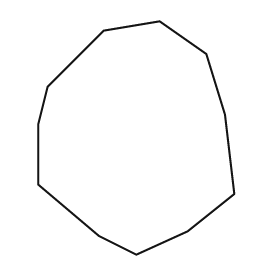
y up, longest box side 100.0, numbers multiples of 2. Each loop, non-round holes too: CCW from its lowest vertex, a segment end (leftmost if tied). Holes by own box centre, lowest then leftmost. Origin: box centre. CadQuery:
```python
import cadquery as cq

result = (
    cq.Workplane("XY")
    .moveTo(0.0, -50.0)
    .lineTo(22.0, -40.0)
    .lineTo(42.0, -24.0)
    .lineTo(38.0, 10.0)
    .lineTo(30.0, 36.0)
    .lineTo(10.0, 50.0)
    .lineTo(-14.0, 46.0)
    .lineTo(-38.0, 22.0)
    .lineTo(-42.0, 6.0)
    .lineTo(-42.0, -20.0)
    .lineTo(-16.0, -42.0)
    .close()
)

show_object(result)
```